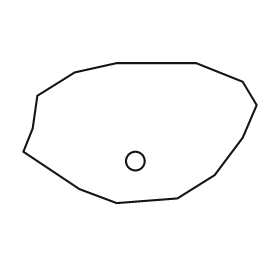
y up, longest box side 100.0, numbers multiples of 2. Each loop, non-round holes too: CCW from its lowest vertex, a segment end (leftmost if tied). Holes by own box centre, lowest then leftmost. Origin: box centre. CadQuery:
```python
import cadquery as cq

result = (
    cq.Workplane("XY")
    .moveTo(-10.0, -30.0)
    .lineTo(16.0, -28.0)
    .lineTo(32.0, -18.0)
    .lineTo(44.0, -2.0)
    .lineTo(50.0, 12.0)
    .lineTo(44.0, 22.0)
    .lineTo(24.0, 30.0)
    .lineTo(-10.0, 30.0)
    .lineTo(-28.0, 26.0)
    .lineTo(-44.0, 16.0)
    .lineTo(-46.0, 2.0)
    .lineTo(-50.0, -8.0)
    .lineTo(-26.0, -24.0)
    .close()
    .moveTo(-2.0, -12.0)
    .circle(4.0)
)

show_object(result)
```